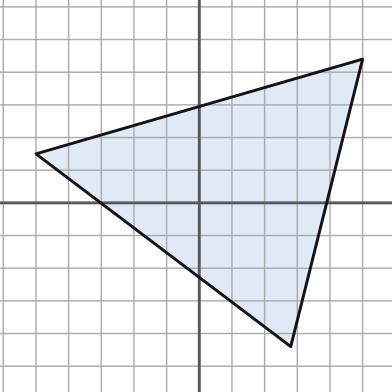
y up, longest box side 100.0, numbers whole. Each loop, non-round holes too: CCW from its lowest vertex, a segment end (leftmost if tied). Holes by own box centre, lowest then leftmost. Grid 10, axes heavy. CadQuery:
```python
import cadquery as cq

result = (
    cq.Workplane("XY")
    .moveTo(28.0, -44.0)
    .lineTo(50.0, 44.0)
    .lineTo(-50.0, 15.0)
    .close()
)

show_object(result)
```